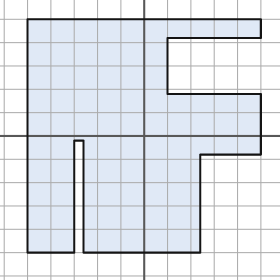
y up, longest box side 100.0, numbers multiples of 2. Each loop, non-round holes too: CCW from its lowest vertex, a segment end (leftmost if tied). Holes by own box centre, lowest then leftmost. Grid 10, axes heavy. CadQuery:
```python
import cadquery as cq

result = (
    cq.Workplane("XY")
    .moveTo(-50.0, -50.0)
    .lineTo(-30.0, -50.0)
    .lineTo(-30.0, -2.0)
    .lineTo(-26.0, -2.0)
    .lineTo(-26.0, -50.0)
    .lineTo(24.0, -50.0)
    .lineTo(24.0, -8.0)
    .lineTo(50.0, -8.0)
    .lineTo(50.0, 18.0)
    .lineTo(10.0, 18.0)
    .lineTo(10.0, 42.0)
    .lineTo(50.0, 42.0)
    .lineTo(50.0, 50.0)
    .lineTo(-50.0, 50.0)
    .close()
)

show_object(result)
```